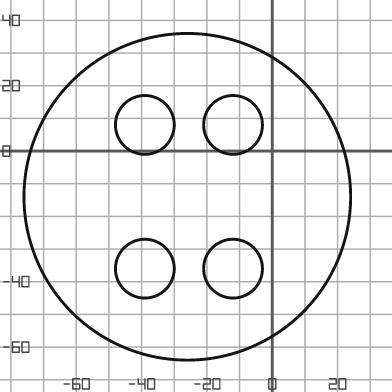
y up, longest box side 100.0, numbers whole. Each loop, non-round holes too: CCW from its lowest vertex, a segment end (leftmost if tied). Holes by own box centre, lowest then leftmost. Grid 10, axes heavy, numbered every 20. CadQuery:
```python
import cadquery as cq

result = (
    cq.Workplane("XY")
    .moveTo(-26.0, -14.0)
    .circle(50.0)
    .moveTo(-39.0, -36.0)
    .circle(9.0)
    .moveTo(-12.0, -36.0)
    .circle(9.0)
    .moveTo(-39.0, 8.0)
    .circle(9.0)
    .moveTo(-12.0, 8.0)
    .circle(9.0)
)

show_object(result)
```